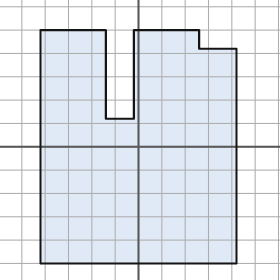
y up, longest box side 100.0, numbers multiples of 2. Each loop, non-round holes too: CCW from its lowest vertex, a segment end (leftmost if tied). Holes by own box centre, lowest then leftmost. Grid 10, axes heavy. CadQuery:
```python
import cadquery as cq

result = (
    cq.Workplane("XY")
    .moveTo(-42.0, -50.0)
    .lineTo(42.0, -50.0)
    .lineTo(42.0, 42.0)
    .lineTo(26.0, 42.0)
    .lineTo(26.0, 50.0)
    .lineTo(-2.0, 50.0)
    .lineTo(-2.0, 12.0)
    .lineTo(-14.0, 12.0)
    .lineTo(-14.0, 50.0)
    .lineTo(-42.0, 50.0)
    .close()
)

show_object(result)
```